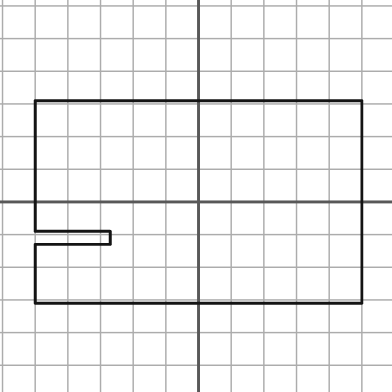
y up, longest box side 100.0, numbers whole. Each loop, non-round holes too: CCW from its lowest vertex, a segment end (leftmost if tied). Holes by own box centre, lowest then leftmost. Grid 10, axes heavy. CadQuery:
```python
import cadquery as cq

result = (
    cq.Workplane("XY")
    .moveTo(-50.0, -31.0)
    .lineTo(50.0, -31.0)
    .lineTo(50.0, 31.0)
    .lineTo(-50.0, 31.0)
    .lineTo(-50.0, -9.0)
    .lineTo(-27.0, -9.0)
    .lineTo(-27.0, -13.0)
    .lineTo(-50.0, -13.0)
    .close()
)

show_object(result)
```